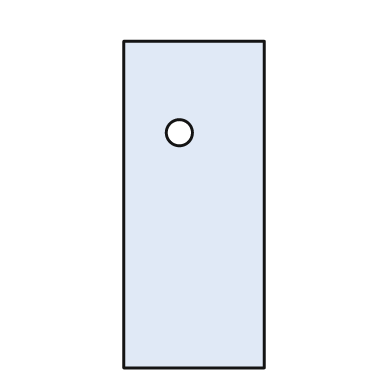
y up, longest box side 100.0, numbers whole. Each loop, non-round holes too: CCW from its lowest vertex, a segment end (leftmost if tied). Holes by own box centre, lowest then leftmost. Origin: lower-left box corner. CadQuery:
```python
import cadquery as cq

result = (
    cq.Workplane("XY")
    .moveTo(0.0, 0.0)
    .lineTo(43.0, 0.0)
    .lineTo(43.0, 100.0)
    .lineTo(0.0, 100.0)
    .close()
    .moveTo(17.0, 72.0)
    .circle(4.0)
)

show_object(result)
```